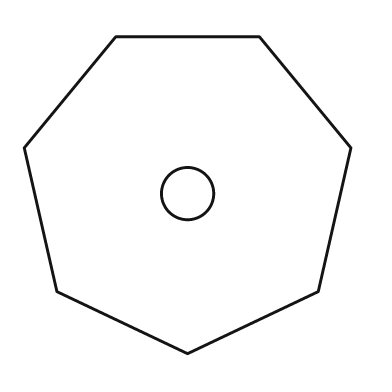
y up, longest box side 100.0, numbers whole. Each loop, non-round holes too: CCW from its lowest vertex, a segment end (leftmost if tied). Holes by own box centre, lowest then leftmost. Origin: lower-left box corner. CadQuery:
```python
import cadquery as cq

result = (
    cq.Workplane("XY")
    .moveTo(50.0, 0.0)
    .lineTo(90.0, 19.0)
    .lineTo(100.0, 63.0)
    .lineTo(72.0, 97.0)
    .lineTo(28.0, 97.0)
    .lineTo(0.0, 63.0)
    .lineTo(10.0, 19.0)
    .close()
    .moveTo(50.0, 49.0)
    .circle(8.0)
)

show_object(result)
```